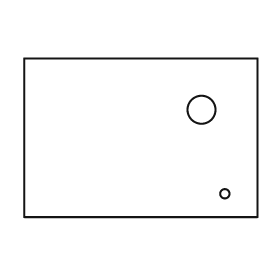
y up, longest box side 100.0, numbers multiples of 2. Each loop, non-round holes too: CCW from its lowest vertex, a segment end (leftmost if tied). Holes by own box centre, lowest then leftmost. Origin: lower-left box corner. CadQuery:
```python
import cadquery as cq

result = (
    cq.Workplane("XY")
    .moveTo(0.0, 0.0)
    .lineTo(100.0, 0.0)
    .lineTo(100.0, 68.0)
    .lineTo(0.0, 68.0)
    .close()
    .moveTo(86.0, 10.0)
    .circle(2.0)
    .moveTo(76.0, 46.0)
    .circle(6.0)
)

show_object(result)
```